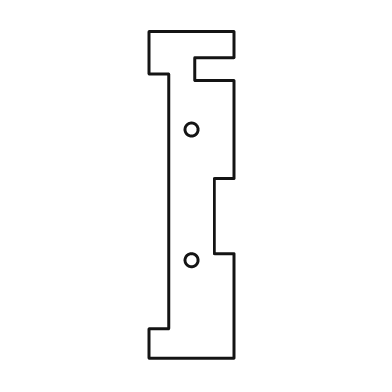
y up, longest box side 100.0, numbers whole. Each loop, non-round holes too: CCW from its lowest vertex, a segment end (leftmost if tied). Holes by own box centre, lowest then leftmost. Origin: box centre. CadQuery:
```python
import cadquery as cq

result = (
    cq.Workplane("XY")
    .moveTo(-13.0, -50.0)
    .lineTo(13.0, -50.0)
    .lineTo(13.0, -18.0)
    .lineTo(7.0, -18.0)
    .lineTo(7.0, 5.0)
    .lineTo(13.0, 5.0)
    .lineTo(13.0, 35.0)
    .lineTo(1.0, 35.0)
    .lineTo(1.0, 42.0)
    .lineTo(13.0, 42.0)
    .lineTo(13.0, 50.0)
    .lineTo(-13.0, 50.0)
    .lineTo(-13.0, 37.0)
    .lineTo(-7.0, 37.0)
    .lineTo(-7.0, -41.0)
    .lineTo(-13.0, -41.0)
    .close()
    .moveTo(0.0, -20.0)
    .circle(2.0)
    .moveTo(0.0, 20.0)
    .circle(2.0)
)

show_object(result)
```